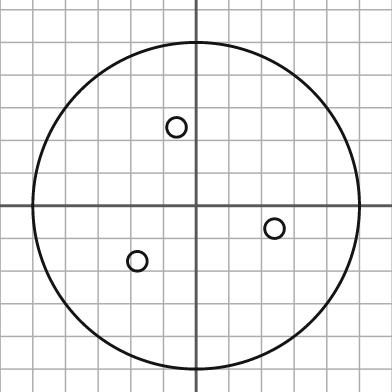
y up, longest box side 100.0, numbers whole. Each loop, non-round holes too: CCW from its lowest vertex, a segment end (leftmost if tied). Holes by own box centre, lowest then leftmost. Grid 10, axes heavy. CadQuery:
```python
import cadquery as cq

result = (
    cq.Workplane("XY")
    .moveTo(0.0, 0.0)
    .circle(50.0)
    .moveTo(-18.0, -17.0)
    .circle(3.0)
    .moveTo(24.0, -7.0)
    .circle(3.0)
    .moveTo(-6.0, 24.0)
    .circle(3.0)
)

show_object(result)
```